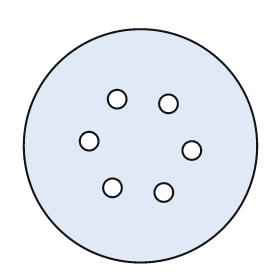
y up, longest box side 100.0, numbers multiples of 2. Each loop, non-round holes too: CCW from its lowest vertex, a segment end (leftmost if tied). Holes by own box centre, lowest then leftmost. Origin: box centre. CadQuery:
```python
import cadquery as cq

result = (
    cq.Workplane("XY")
    .moveTo(0.0, 0.0)
    .circle(50.0)
    .moveTo(10.0, -20.0)
    .circle(4.0)
    .moveTo(-12.0, -18.0)
    .circle(4.0)
    .moveTo(22.0, -2.0)
    .circle(4.0)
    .moveTo(-22.0, 2.0)
    .circle(4.0)
    .moveTo(12.0, 18.0)
    .circle(4.0)
    .moveTo(-10.0, 20.0)
    .circle(4.0)
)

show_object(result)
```